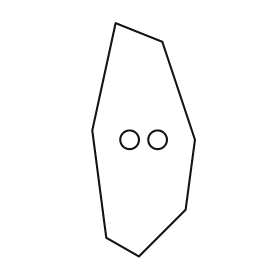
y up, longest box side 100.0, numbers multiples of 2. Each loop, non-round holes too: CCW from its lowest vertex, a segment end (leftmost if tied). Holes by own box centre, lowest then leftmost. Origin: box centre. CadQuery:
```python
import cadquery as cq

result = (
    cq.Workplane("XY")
    .moveTo(-2.0, -50.0)
    .lineTo(18.0, -30.0)
    .lineTo(22.0, 0.0)
    .lineTo(8.0, 42.0)
    .lineTo(-12.0, 50.0)
    .lineTo(-22.0, 4.0)
    .lineTo(-16.0, -42.0)
    .close()
    .moveTo(-6.0, 0.0)
    .circle(4.0)
    .moveTo(6.0, 0.0)
    .circle(4.0)
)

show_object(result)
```